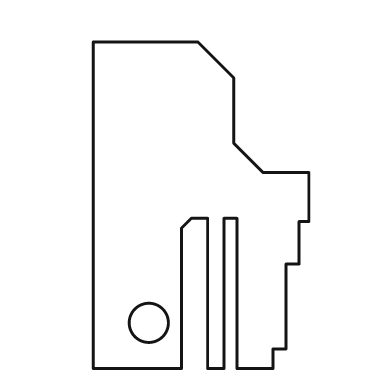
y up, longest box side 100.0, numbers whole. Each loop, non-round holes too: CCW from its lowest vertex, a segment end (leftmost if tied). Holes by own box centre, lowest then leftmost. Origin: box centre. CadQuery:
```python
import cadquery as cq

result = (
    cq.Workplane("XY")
    .moveTo(-33.0, -50.0)
    .lineTo(-6.0, -50.0)
    .lineTo(-6.0, -7.0)
    .lineTo(-3.0, -4.0)
    .lineTo(2.0, -4.0)
    .lineTo(2.0, -50.0)
    .lineTo(7.0, -50.0)
    .lineTo(7.0, -4.0)
    .lineTo(11.0, -4.0)
    .lineTo(11.0, -50.0)
    .lineTo(22.0, -50.0)
    .lineTo(22.0, -44.0)
    .lineTo(26.0, -44.0)
    .lineTo(26.0, -18.0)
    .lineTo(30.0, -18.0)
    .lineTo(30.0, -5.0)
    .lineTo(33.0, -5.0)
    .lineTo(33.0, 10.0)
    .lineTo(19.0, 10.0)
    .lineTo(10.0, 19.0)
    .lineTo(10.0, 39.0)
    .lineTo(-1.0, 50.0)
    .lineTo(-33.0, 50.0)
    .close()
    .moveTo(-16.0, -36.0)
    .circle(6.0)
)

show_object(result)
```